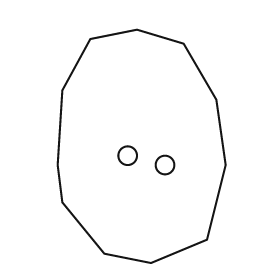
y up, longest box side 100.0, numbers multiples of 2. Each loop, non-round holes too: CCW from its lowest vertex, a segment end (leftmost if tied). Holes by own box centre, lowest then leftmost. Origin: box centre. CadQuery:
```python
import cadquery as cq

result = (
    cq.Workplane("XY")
    .moveTo(4.0, -50.0)
    .lineTo(28.0, -40.0)
    .lineTo(36.0, -8.0)
    .lineTo(32.0, 20.0)
    .lineTo(18.0, 44.0)
    .lineTo(-2.0, 50.0)
    .lineTo(-22.0, 46.0)
    .lineTo(-34.0, 24.0)
    .lineTo(-36.0, -8.0)
    .lineTo(-34.0, -24.0)
    .lineTo(-16.0, -46.0)
    .close()
    .moveTo(10.0, -8.0)
    .circle(4.0)
    .moveTo(-6.0, -4.0)
    .circle(4.0)
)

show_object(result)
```